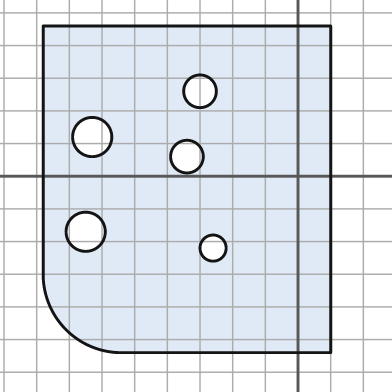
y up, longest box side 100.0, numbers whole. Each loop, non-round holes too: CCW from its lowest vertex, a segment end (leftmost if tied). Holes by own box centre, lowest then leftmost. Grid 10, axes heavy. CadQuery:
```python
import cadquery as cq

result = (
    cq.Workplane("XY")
    .moveTo(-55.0, -54.0)
    .lineTo(10.0, -54.0)
    .lineTo(10.0, 46.0)
    .lineTo(-78.0, 46.0)
    .lineTo(-78.0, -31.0)
    .threePointArc((-71.0, -47.0), (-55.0, -54.0))
    .close()
    .moveTo(-26.0, -22.0)
    .circle(4.0)
    .moveTo(-65.0, -17.0)
    .circle(6.0)
    .moveTo(-34.0, 6.0)
    .circle(5.0)
    .moveTo(-63.0, 12.0)
    .circle(6.0)
    .moveTo(-30.0, 26.0)
    .circle(5.0)
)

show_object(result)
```